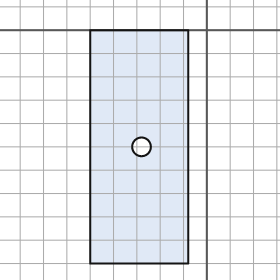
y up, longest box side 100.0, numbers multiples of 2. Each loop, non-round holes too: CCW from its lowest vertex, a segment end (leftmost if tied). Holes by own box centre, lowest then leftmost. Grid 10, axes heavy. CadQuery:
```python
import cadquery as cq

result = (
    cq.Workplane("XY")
    .moveTo(-50.0, -100.0)
    .lineTo(-8.0, -100.0)
    .lineTo(-8.0, 0.0)
    .lineTo(-50.0, 0.0)
    .close()
    .moveTo(-28.0, -50.0)
    .circle(4.0)
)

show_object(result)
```